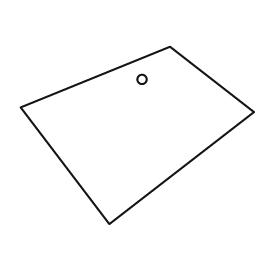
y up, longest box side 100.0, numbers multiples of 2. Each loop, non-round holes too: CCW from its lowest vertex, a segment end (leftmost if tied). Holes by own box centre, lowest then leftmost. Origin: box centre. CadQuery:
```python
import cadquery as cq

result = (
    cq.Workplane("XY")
    .moveTo(-12.0, -38.0)
    .lineTo(50.0, 10.0)
    .lineTo(14.0, 38.0)
    .lineTo(-50.0, 12.0)
    .close()
    .moveTo(2.0, 24.0)
    .circle(2.0)
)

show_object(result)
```